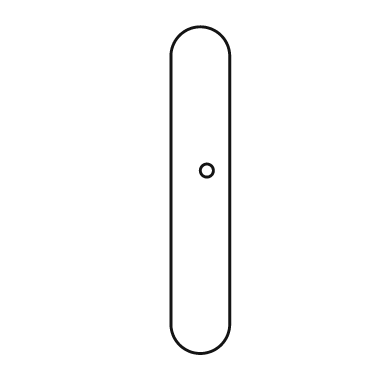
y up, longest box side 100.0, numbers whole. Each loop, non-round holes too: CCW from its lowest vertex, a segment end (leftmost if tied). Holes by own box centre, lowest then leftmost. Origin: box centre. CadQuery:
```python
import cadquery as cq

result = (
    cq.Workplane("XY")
    .moveTo(-9.0, -41.0)
    .threePointArc((0.0, -50.0), (9.0, -41.0))
    .lineTo(9.0, 41.0)
    .threePointArc((0.0, 50.0), (-9.0, 41.0))
    .close()
    .moveTo(2.0, 6.0)
    .circle(2.0)
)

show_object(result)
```